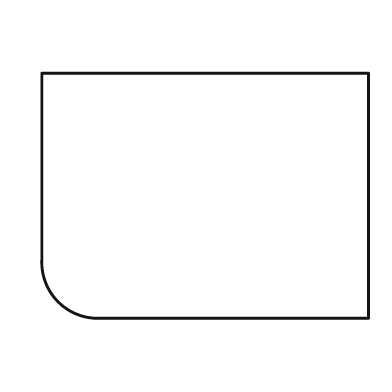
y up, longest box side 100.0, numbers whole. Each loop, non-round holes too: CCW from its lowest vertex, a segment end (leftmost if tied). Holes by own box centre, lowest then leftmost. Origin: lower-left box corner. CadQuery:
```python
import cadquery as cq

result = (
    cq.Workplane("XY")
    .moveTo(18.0, 0.0)
    .lineTo(100.0, 0.0)
    .lineTo(100.0, 75.0)
    .lineTo(0.0, 75.0)
    .lineTo(0.0, 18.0)
    .threePointArc((5.0, 5.0), (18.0, 0.0))
    .close()
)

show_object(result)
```